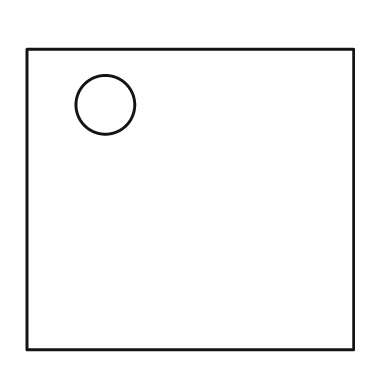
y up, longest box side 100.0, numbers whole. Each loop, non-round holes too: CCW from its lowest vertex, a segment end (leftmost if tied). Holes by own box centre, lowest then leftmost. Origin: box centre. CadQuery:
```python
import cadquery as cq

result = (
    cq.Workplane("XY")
    .moveTo(-50.0, -46.0)
    .lineTo(50.0, -46.0)
    .lineTo(50.0, 46.0)
    .lineTo(-50.0, 46.0)
    .close()
    .moveTo(-26.0, 29.0)
    .circle(9.0)
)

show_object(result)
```